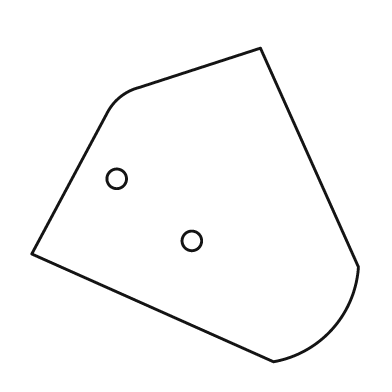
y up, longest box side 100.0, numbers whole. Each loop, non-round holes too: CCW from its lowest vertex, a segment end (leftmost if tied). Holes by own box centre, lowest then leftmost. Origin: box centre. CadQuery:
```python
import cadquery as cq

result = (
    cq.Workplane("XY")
    .moveTo(24.0, -48.0)
    .threePointArc((42.0, -38.0), (50.0, -19.0))
    .lineTo(20.0, 48.0)
    .lineTo(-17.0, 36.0)
    .threePointArc((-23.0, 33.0), (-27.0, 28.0))
    .lineTo(-50.0, -15.0)
    .close()
    .moveTo(-1.0, -11.0)
    .circle(3.0)
    .moveTo(-24.0, 8.0)
    .circle(3.0)
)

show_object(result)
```